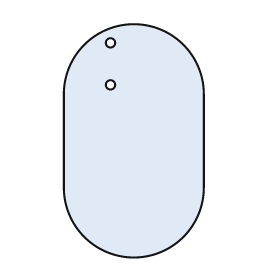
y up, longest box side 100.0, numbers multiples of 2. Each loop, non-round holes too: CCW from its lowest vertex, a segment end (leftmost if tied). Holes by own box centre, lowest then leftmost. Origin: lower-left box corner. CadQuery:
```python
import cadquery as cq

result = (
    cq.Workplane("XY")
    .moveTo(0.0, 30.0)
    .threePointArc((30.0, 0.0), (60.0, 30.0))
    .lineTo(60.0, 70.0)
    .threePointArc((30.0, 100.0), (0.0, 70.0))
    .close()
    .moveTo(20.0, 74.0)
    .circle(2.0)
    .moveTo(20.0, 92.0)
    .circle(2.0)
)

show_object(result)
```